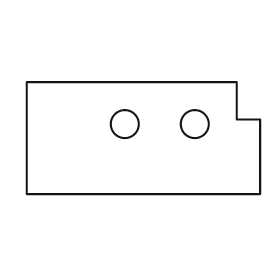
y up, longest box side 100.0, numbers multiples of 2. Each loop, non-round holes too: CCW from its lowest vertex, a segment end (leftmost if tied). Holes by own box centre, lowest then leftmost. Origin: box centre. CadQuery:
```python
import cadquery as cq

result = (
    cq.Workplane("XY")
    .moveTo(-50.0, -24.0)
    .lineTo(50.0, -24.0)
    .lineTo(50.0, 8.0)
    .lineTo(40.0, 8.0)
    .lineTo(40.0, 24.0)
    .lineTo(-50.0, 24.0)
    .close()
    .moveTo(-8.0, 6.0)
    .circle(6.0)
    .moveTo(22.0, 6.0)
    .circle(6.0)
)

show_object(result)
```